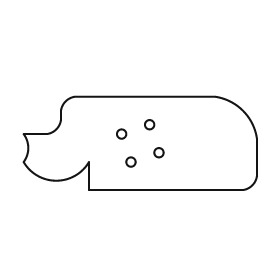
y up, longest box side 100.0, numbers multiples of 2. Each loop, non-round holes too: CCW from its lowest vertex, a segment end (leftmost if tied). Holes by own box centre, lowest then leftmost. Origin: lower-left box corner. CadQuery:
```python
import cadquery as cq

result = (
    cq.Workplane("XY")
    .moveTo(28.0, 0.0)
    .lineTo(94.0, 0.0)
    .threePointArc((98.0, 2.0), (100.0, 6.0))
    .lineTo(100.0, 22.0)
    .threePointArc((94.0, 34.0), (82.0, 40.0))
    .lineTo(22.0, 40.0)
    .threePointArc((18.0, 38.0), (16.0, 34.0))
    .lineTo(16.0, 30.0)
    .threePointArc((14.0, 26.0), (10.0, 24.0))
    .lineTo(0.0, 24.0)
    .threePointArc((2.0, 18.0), (0.0, 12.0))
    .threePointArc((14.0, 4.0), (28.0, 12.0))
    .close()
    .moveTo(46.0, 12.0)
    .circle(2.0)
    .moveTo(58.0, 16.0)
    .circle(2.0)
    .moveTo(42.0, 24.0)
    .circle(2.0)
    .moveTo(54.0, 28.0)
    .circle(2.0)
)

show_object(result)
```